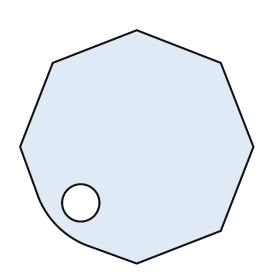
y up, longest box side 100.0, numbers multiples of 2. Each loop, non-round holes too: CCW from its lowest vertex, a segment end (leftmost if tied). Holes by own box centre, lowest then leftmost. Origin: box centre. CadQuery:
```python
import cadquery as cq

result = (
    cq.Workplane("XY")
    .moveTo(0.0, -50.0)
    .lineTo(36.0, -36.0)
    .lineTo(50.0, 0.0)
    .lineTo(36.0, 36.0)
    .lineTo(0.0, 50.0)
    .lineTo(-36.0, 36.0)
    .lineTo(-50.0, 0.0)
    .lineTo(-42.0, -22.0)
    .threePointArc((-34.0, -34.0), (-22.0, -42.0))
    .close()
    .moveTo(-24.0, -24.0)
    .circle(8.0)
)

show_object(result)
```